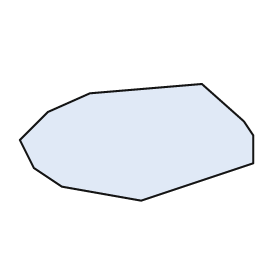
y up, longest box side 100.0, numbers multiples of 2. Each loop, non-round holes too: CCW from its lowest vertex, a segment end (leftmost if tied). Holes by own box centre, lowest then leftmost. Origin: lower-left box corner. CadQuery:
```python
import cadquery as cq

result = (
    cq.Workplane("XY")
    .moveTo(52.0, 0.0)
    .lineTo(100.0, 16.0)
    .lineTo(100.0, 28.0)
    .lineTo(96.0, 34.0)
    .lineTo(78.0, 50.0)
    .lineTo(30.0, 46.0)
    .lineTo(12.0, 38.0)
    .lineTo(0.0, 26.0)
    .lineTo(6.0, 14.0)
    .lineTo(18.0, 6.0)
    .close()
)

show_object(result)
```